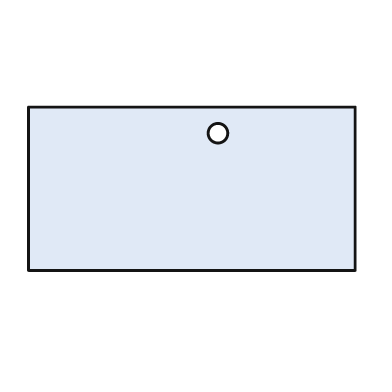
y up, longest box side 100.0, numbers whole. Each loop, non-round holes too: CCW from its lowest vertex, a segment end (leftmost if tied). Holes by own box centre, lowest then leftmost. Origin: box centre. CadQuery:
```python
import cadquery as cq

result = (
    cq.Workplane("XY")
    .moveTo(-50.0, -25.0)
    .lineTo(50.0, -25.0)
    .lineTo(50.0, 25.0)
    .lineTo(-50.0, 25.0)
    .close()
    .moveTo(8.0, 17.0)
    .circle(3.0)
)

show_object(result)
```